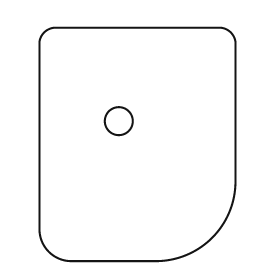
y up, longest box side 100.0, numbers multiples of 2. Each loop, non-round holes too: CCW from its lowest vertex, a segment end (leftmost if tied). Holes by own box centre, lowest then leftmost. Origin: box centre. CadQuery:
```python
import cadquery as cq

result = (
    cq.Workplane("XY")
    .moveTo(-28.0, -50.0)
    .lineTo(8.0, -50.0)
    .threePointArc((32.0, -40.0), (42.0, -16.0))
    .lineTo(42.0, 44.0)
    .threePointArc((40.0, 48.0), (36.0, 50.0))
    .lineTo(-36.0, 50.0)
    .threePointArc((-40.0, 48.0), (-42.0, 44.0))
    .lineTo(-42.0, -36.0)
    .threePointArc((-38.0, -46.0), (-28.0, -50.0))
    .close()
    .moveTo(-8.0, 10.0)
    .circle(6.0)
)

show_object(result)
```